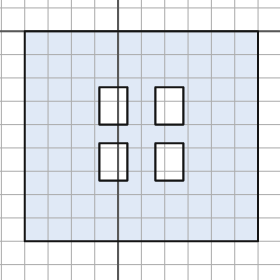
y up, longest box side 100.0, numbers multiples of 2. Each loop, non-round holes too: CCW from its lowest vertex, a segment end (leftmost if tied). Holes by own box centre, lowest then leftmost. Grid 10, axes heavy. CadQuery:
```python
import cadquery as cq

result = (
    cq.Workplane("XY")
    .moveTo(-40.0, -90.0)
    .lineTo(60.0, -90.0)
    .lineTo(60.0, 0.0)
    .lineTo(-40.0, 0.0)
    .close()
    .moveTo(-8.0, -64.0)
    .lineTo(4.0, -64.0)
    .lineTo(4.0, -48.0)
    .lineTo(-8.0, -48.0)
    .close()
    .moveTo(16.0, -64.0)
    .lineTo(28.0, -64.0)
    .lineTo(28.0, -48.0)
    .lineTo(16.0, -48.0)
    .close()
    .moveTo(-8.0, -40.0)
    .lineTo(4.0, -40.0)
    .lineTo(4.0, -24.0)
    .lineTo(-8.0, -24.0)
    .close()
    .moveTo(16.0, -40.0)
    .lineTo(28.0, -40.0)
    .lineTo(28.0, -24.0)
    .lineTo(16.0, -24.0)
    .close()
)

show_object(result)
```